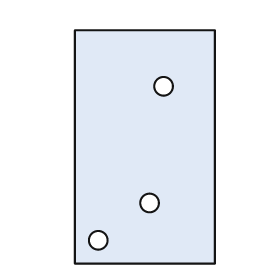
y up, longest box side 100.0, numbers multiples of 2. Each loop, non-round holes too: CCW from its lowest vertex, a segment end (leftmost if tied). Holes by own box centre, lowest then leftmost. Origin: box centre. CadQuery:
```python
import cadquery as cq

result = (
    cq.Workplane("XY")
    .moveTo(-30.0, -50.0)
    .lineTo(30.0, -50.0)
    .lineTo(30.0, 50.0)
    .lineTo(-30.0, 50.0)
    .close()
    .moveTo(-20.0, -40.0)
    .circle(4.0)
    .moveTo(2.0, -24.0)
    .circle(4.0)
    .moveTo(8.0, 26.0)
    .circle(4.0)
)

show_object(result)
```